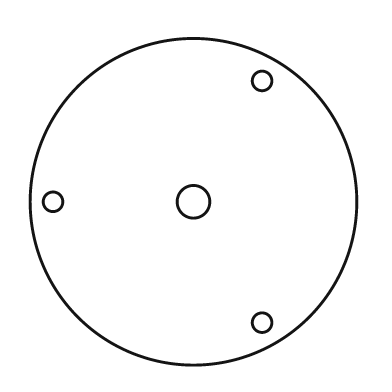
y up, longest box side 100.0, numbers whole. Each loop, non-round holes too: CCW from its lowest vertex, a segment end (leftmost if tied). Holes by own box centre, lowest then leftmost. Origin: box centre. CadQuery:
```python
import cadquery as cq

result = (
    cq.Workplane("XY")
    .moveTo(0.0, 0.0)
    .circle(50.0)
    .moveTo(21.0, -37.0)
    .circle(3.0)
    .moveTo(-43.0, 0.0)
    .circle(3.0)
    .moveTo(0.0, 0.0)
    .circle(5.0)
    .moveTo(21.0, 37.0)
    .circle(3.0)
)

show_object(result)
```